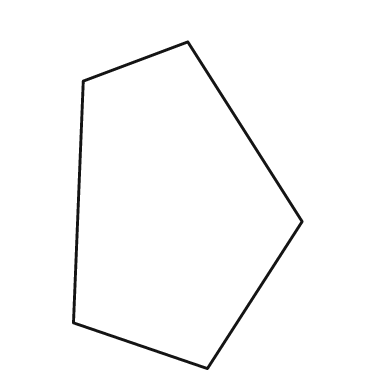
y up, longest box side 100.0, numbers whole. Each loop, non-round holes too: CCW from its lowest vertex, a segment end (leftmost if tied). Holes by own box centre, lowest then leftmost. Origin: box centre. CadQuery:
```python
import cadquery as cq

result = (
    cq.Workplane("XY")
    .moveTo(6.0, -50.0)
    .lineTo(35.0, -5.0)
    .lineTo(0.0, 50.0)
    .lineTo(-32.0, 38.0)
    .lineTo(-35.0, -36.0)
    .close()
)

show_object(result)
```